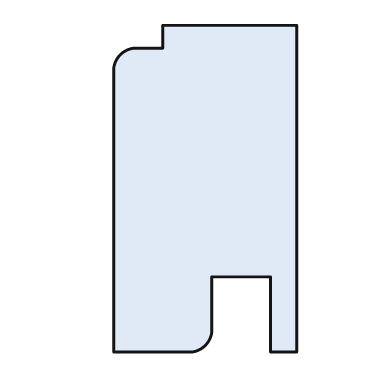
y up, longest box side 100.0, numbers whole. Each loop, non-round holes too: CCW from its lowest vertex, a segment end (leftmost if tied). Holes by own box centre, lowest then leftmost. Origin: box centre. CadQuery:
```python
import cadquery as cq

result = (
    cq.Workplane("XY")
    .moveTo(-28.0, -50.0)
    .lineTo(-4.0, -50.0)
    .threePointArc((0.0, -48.0), (2.0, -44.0))
    .lineTo(2.0, -27.0)
    .lineTo(20.0, -27.0)
    .lineTo(20.0, -50.0)
    .lineTo(28.0, -50.0)
    .lineTo(28.0, 50.0)
    .lineTo(-13.0, 50.0)
    .lineTo(-13.0, 43.0)
    .lineTo(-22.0, 43.0)
    .threePointArc((-26.0, 41.0), (-28.0, 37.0))
    .close()
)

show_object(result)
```